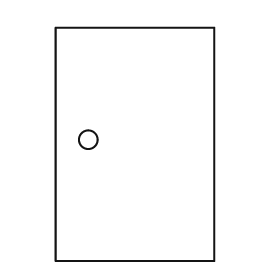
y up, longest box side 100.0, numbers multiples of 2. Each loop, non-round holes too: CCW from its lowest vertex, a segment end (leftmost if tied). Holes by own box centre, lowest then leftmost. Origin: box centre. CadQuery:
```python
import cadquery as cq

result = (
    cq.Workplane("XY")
    .moveTo(-34.0, -50.0)
    .lineTo(34.0, -50.0)
    .lineTo(34.0, 50.0)
    .lineTo(-34.0, 50.0)
    .close()
    .moveTo(-20.0, 2.0)
    .circle(4.0)
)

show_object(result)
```